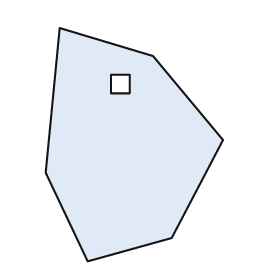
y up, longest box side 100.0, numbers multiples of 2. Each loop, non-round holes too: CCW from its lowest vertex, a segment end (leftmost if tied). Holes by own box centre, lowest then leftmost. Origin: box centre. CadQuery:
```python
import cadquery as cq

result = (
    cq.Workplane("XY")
    .moveTo(-20.0, -50.0)
    .lineTo(16.0, -40.0)
    .lineTo(38.0, 2.0)
    .lineTo(8.0, 38.0)
    .lineTo(-32.0, 50.0)
    .lineTo(-38.0, -12.0)
    .close()
    .moveTo(-10.0, 22.0)
    .lineTo(-2.0, 22.0)
    .lineTo(-2.0, 30.0)
    .lineTo(-10.0, 30.0)
    .close()
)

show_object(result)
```